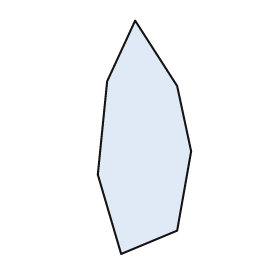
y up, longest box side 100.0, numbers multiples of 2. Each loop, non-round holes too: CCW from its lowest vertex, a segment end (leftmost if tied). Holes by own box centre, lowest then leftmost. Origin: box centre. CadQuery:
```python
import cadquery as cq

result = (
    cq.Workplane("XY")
    .moveTo(-10.0, -50.0)
    .lineTo(14.0, -40.0)
    .lineTo(20.0, -6.0)
    .lineTo(14.0, 22.0)
    .lineTo(-4.0, 50.0)
    .lineTo(-16.0, 24.0)
    .lineTo(-20.0, -16.0)
    .close()
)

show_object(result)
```